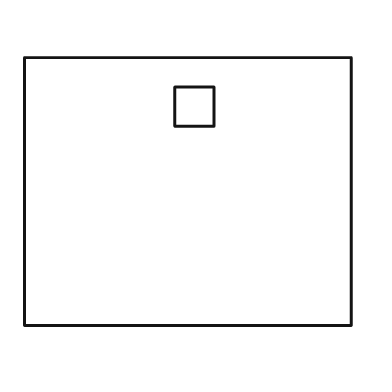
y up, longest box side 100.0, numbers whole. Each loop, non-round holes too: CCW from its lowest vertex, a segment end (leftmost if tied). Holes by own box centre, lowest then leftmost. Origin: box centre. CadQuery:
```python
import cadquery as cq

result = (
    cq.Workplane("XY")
    .moveTo(-50.0, -41.0)
    .lineTo(50.0, -41.0)
    .lineTo(50.0, 41.0)
    .lineTo(-50.0, 41.0)
    .close()
    .moveTo(-4.0, 20.0)
    .lineTo(8.0, 20.0)
    .lineTo(8.0, 32.0)
    .lineTo(-4.0, 32.0)
    .close()
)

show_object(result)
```